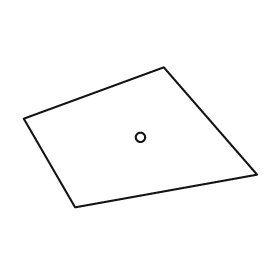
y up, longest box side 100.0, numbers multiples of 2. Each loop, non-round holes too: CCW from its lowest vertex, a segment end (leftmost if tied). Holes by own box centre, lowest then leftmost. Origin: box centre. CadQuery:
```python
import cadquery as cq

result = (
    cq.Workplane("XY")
    .moveTo(-28.0, -30.0)
    .lineTo(50.0, -16.0)
    .lineTo(10.0, 30.0)
    .lineTo(-50.0, 8.0)
    .close()
    .moveTo(0.0, 0.0)
    .circle(2.0)
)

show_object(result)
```